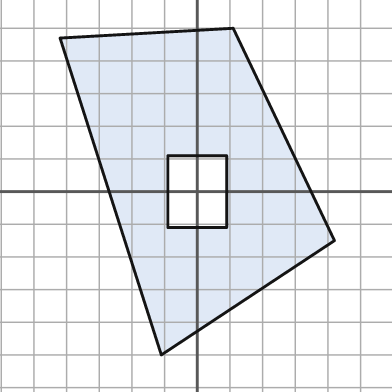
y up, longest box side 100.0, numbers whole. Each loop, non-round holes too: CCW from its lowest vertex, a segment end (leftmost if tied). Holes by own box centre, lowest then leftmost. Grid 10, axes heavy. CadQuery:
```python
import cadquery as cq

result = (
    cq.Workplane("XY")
    .moveTo(-11.0, -50.0)
    .lineTo(42.0, -15.0)
    .lineTo(11.0, 50.0)
    .lineTo(-42.0, 47.0)
    .close()
    .moveTo(-9.0, -11.0)
    .lineTo(9.0, -11.0)
    .lineTo(9.0, 11.0)
    .lineTo(-9.0, 11.0)
    .close()
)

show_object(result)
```